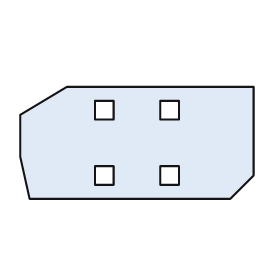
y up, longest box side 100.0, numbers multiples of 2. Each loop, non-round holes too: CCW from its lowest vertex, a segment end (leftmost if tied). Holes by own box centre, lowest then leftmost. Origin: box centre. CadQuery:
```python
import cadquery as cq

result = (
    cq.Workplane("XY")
    .moveTo(-46.0, -24.0)
    .lineTo(40.0, -24.0)
    .lineTo(50.0, -14.0)
    .lineTo(50.0, 24.0)
    .lineTo(-30.0, 24.0)
    .lineTo(-50.0, 12.0)
    .lineTo(-50.0, -6.0)
    .close()
    .moveTo(-18.0, -18.0)
    .lineTo(-10.0, -18.0)
    .lineTo(-10.0, -10.0)
    .lineTo(-18.0, -10.0)
    .close()
    .moveTo(10.0, -18.0)
    .lineTo(18.0, -18.0)
    .lineTo(18.0, -10.0)
    .lineTo(10.0, -10.0)
    .close()
    .moveTo(-18.0, 10.0)
    .lineTo(-10.0, 10.0)
    .lineTo(-10.0, 18.0)
    .lineTo(-18.0, 18.0)
    .close()
    .moveTo(10.0, 10.0)
    .lineTo(18.0, 10.0)
    .lineTo(18.0, 18.0)
    .lineTo(10.0, 18.0)
    .close()
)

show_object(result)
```